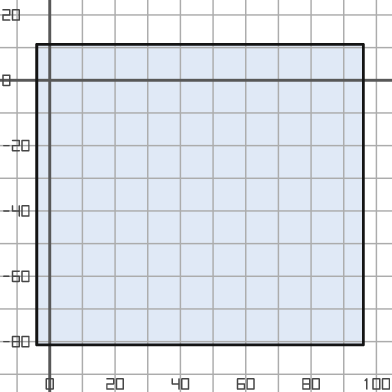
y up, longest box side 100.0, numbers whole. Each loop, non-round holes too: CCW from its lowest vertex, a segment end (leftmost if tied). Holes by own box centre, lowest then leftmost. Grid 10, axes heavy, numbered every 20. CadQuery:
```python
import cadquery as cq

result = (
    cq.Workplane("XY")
    .moveTo(-4.0, -81.0)
    .lineTo(96.0, -81.0)
    .lineTo(96.0, 11.0)
    .lineTo(-4.0, 11.0)
    .close()
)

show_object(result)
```